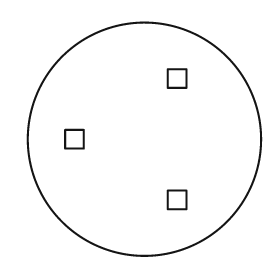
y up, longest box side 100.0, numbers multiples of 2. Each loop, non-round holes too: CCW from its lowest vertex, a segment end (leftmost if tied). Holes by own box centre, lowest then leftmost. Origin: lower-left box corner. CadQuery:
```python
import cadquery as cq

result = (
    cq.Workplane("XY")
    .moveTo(50.0, 50.0)
    .circle(50.0)
    .moveTo(60.0, 20.0)
    .lineTo(68.0, 20.0)
    .lineTo(68.0, 28.0)
    .lineTo(60.0, 28.0)
    .close()
    .moveTo(16.0, 46.0)
    .lineTo(24.0, 46.0)
    .lineTo(24.0, 54.0)
    .lineTo(16.0, 54.0)
    .close()
    .moveTo(60.0, 72.0)
    .lineTo(68.0, 72.0)
    .lineTo(68.0, 80.0)
    .lineTo(60.0, 80.0)
    .close()
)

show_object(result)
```